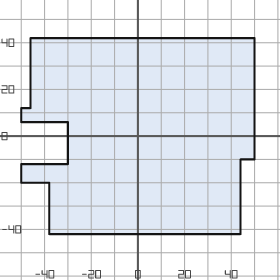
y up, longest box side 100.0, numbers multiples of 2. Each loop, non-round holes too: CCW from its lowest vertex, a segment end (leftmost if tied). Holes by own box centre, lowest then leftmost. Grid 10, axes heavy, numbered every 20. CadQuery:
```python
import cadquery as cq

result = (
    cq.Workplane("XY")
    .moveTo(-38.0, -42.0)
    .lineTo(44.0, -42.0)
    .lineTo(44.0, -10.0)
    .lineTo(50.0, -10.0)
    .lineTo(50.0, 42.0)
    .lineTo(-46.0, 42.0)
    .lineTo(-46.0, 12.0)
    .lineTo(-50.0, 12.0)
    .lineTo(-50.0, 6.0)
    .lineTo(-30.0, 6.0)
    .lineTo(-30.0, -12.0)
    .lineTo(-50.0, -12.0)
    .lineTo(-50.0, -20.0)
    .lineTo(-38.0, -20.0)
    .close()
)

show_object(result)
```